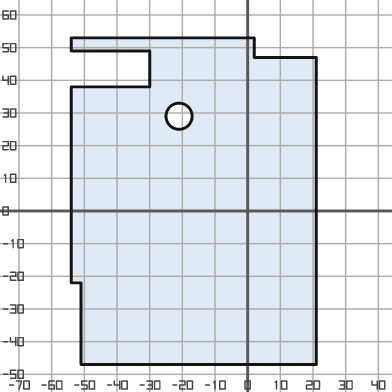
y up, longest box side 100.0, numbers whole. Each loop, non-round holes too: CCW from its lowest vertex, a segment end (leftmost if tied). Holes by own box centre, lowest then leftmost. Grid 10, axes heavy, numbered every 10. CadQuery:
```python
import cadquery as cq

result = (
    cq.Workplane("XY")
    .moveTo(-51.0, -47.0)
    .lineTo(21.0, -47.0)
    .lineTo(21.0, 47.0)
    .lineTo(2.0, 47.0)
    .lineTo(2.0, 53.0)
    .lineTo(-54.0, 53.0)
    .lineTo(-54.0, 49.0)
    .lineTo(-30.0, 49.0)
    .lineTo(-30.0, 38.0)
    .lineTo(-54.0, 38.0)
    .lineTo(-54.0, -22.0)
    .lineTo(-51.0, -22.0)
    .close()
    .moveTo(-21.0, 29.0)
    .circle(4.0)
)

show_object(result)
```